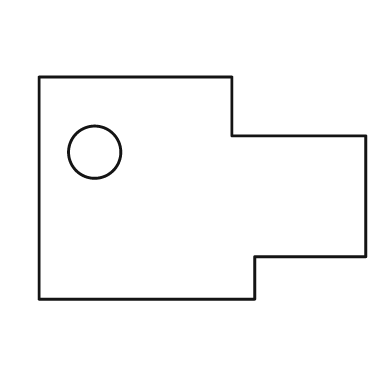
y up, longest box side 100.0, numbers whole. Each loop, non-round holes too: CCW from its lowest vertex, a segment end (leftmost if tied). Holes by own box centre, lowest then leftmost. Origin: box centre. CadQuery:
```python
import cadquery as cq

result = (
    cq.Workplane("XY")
    .moveTo(-50.0, -34.0)
    .lineTo(16.0, -34.0)
    .lineTo(16.0, -21.0)
    .lineTo(50.0, -21.0)
    .lineTo(50.0, 16.0)
    .lineTo(9.0, 16.0)
    .lineTo(9.0, 34.0)
    .lineTo(-50.0, 34.0)
    .close()
    .moveTo(-33.0, 11.0)
    .circle(8.0)
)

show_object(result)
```